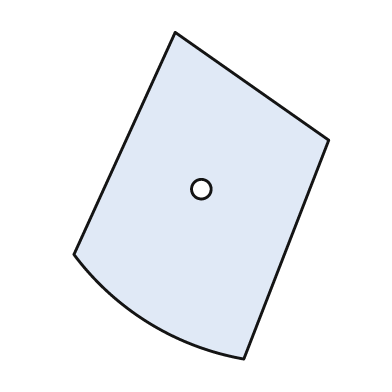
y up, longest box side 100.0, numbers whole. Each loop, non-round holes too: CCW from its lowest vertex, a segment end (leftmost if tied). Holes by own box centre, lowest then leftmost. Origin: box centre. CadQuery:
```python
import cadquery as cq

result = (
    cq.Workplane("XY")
    .moveTo(13.0, -50.0)
    .lineTo(39.0, 17.0)
    .lineTo(-8.0, 50.0)
    .lineTo(-39.0, -18.0)
    .threePointArc((-16.0, -39.0), (13.0, -50.0))
    .close()
    .moveTo(0.0, 2.0)
    .circle(3.0)
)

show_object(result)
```